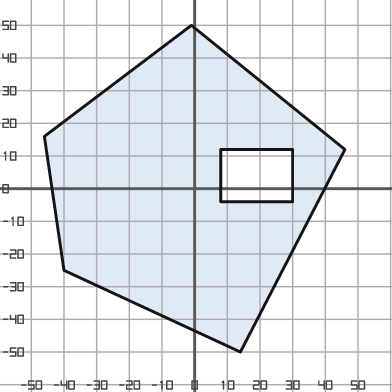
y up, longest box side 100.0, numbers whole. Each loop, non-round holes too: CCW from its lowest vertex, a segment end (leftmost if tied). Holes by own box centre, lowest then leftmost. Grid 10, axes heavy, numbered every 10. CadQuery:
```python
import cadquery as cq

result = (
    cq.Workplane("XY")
    .moveTo(14.0, -50.0)
    .lineTo(46.0, 12.0)
    .lineTo(-1.0, 50.0)
    .lineTo(-46.0, 16.0)
    .lineTo(-40.0, -25.0)
    .close()
    .moveTo(8.0, -4.0)
    .lineTo(30.0, -4.0)
    .lineTo(30.0, 12.0)
    .lineTo(8.0, 12.0)
    .close()
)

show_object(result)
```